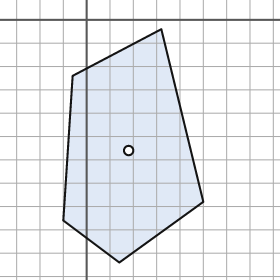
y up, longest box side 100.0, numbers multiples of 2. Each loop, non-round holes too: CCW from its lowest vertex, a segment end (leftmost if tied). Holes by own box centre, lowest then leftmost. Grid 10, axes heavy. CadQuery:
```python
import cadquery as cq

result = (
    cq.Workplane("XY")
    .moveTo(14.0, -104.0)
    .lineTo(50.0, -78.0)
    .lineTo(32.0, -4.0)
    .lineTo(-6.0, -24.0)
    .lineTo(-10.0, -86.0)
    .close()
    .moveTo(18.0, -56.0)
    .circle(2.0)
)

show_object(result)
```